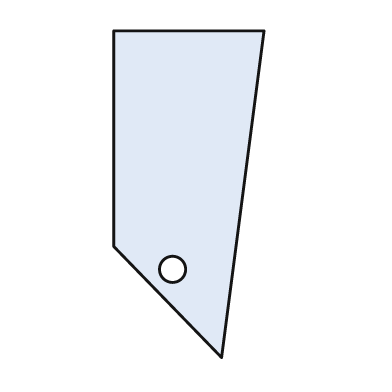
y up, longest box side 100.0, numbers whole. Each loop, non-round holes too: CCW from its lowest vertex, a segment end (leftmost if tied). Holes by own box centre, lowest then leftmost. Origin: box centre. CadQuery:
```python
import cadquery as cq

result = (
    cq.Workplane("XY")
    .moveTo(10.0, -50.0)
    .lineTo(23.0, 50.0)
    .lineTo(-23.0, 50.0)
    .lineTo(-23.0, -16.0)
    .close()
    .moveTo(-5.0, -23.0)
    .circle(4.0)
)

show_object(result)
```